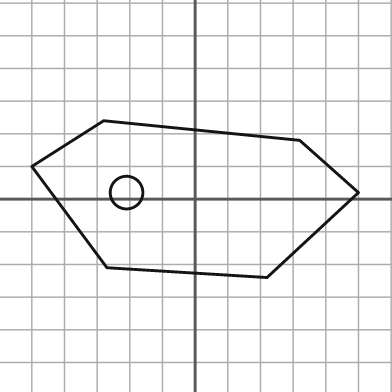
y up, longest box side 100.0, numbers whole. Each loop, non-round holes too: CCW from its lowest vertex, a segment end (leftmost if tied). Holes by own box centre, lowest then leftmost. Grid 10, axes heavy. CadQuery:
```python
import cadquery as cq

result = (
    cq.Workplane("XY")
    .moveTo(22.0, -24.0)
    .lineTo(50.0, 2.0)
    .lineTo(32.0, 18.0)
    .lineTo(-28.0, 24.0)
    .lineTo(-50.0, 10.0)
    .lineTo(-27.0, -21.0)
    .close()
    .moveTo(-21.0, 2.0)
    .circle(5.0)
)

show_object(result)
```